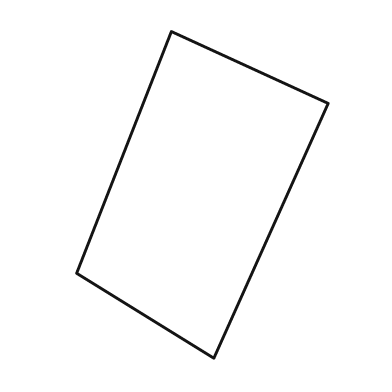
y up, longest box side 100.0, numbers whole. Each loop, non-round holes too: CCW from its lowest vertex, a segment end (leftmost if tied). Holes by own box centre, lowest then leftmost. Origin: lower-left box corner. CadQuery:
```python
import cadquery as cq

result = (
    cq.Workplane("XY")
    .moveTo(42.0, 0.0)
    .lineTo(77.0, 78.0)
    .lineTo(29.0, 100.0)
    .lineTo(0.0, 26.0)
    .close()
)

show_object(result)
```